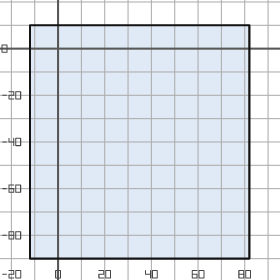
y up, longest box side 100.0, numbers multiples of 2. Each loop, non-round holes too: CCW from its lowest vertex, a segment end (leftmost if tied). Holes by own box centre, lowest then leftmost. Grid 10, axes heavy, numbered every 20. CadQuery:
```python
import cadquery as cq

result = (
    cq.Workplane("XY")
    .moveTo(-12.0, -90.0)
    .lineTo(82.0, -90.0)
    .lineTo(82.0, 10.0)
    .lineTo(-12.0, 10.0)
    .close()
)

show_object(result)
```